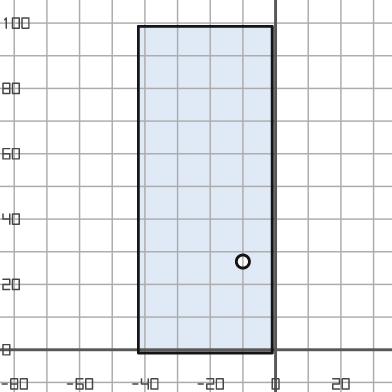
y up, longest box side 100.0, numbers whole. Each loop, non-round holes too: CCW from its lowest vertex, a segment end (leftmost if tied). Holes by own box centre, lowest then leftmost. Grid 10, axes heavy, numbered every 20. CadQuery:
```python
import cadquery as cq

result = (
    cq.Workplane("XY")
    .moveTo(-42.0, -1.0)
    .lineTo(-1.0, -1.0)
    .lineTo(-1.0, 99.0)
    .lineTo(-42.0, 99.0)
    .close()
    .moveTo(-10.0, 27.0)
    .circle(2.0)
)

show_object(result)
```